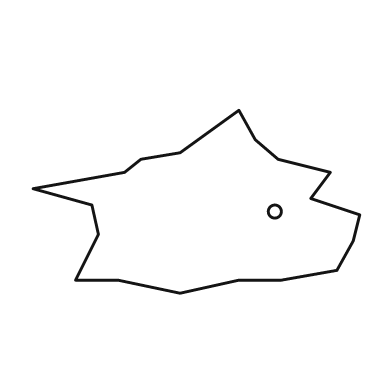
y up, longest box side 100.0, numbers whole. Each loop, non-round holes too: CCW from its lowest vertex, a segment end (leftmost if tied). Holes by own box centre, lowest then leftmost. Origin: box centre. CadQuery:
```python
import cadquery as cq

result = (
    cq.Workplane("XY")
    .moveTo(-5.0, -28.0)
    .lineTo(13.0, -24.0)
    .lineTo(26.0, -24.0)
    .lineTo(43.0, -21.0)
    .lineTo(48.0, -12.0)
    .lineTo(50.0, -4.0)
    .lineTo(35.0, 1.0)
    .lineTo(41.0, 9.0)
    .lineTo(25.0, 13.0)
    .lineTo(18.0, 19.0)
    .lineTo(13.0, 28.0)
    .lineTo(-5.0, 15.0)
    .lineTo(-17.0, 13.0)
    .lineTo(-22.0, 9.0)
    .lineTo(-50.0, 4.0)
    .lineTo(-32.0, -1.0)
    .lineTo(-30.0, -10.0)
    .lineTo(-37.0, -24.0)
    .lineTo(-24.0, -24.0)
    .close()
    .moveTo(24.0, -3.0)
    .circle(2.0)
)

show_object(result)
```